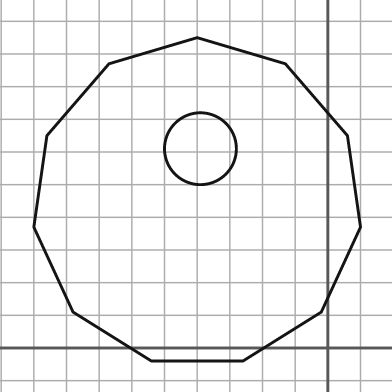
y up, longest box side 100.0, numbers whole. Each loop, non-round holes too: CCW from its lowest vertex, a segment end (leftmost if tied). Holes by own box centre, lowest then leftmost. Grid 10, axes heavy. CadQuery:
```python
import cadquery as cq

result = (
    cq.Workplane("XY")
    .moveTo(-54.0, -4.0)
    .lineTo(-26.0, -4.0)
    .lineTo(-2.0, 11.0)
    .lineTo(10.0, 37.0)
    .lineTo(6.0, 65.0)
    .lineTo(-13.0, 87.0)
    .lineTo(-40.0, 95.0)
    .lineTo(-67.0, 87.0)
    .lineTo(-86.0, 65.0)
    .lineTo(-90.0, 37.0)
    .lineTo(-78.0, 11.0)
    .close()
    .moveTo(-39.0, 61.0)
    .circle(11.0)
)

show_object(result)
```